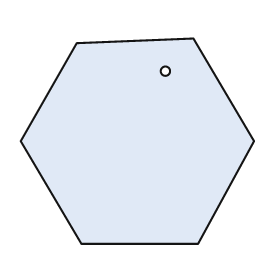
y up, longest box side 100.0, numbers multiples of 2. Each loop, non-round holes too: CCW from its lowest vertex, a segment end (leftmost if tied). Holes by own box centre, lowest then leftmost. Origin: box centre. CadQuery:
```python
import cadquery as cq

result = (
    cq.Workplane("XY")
    .moveTo(-24.0, -44.0)
    .lineTo(26.0, -44.0)
    .lineTo(50.0, 0.0)
    .lineTo(24.0, 44.0)
    .lineTo(-26.0, 42.0)
    .lineTo(-50.0, 0.0)
    .close()
    .moveTo(12.0, 30.0)
    .circle(2.0)
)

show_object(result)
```